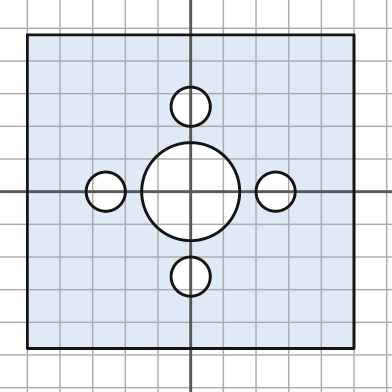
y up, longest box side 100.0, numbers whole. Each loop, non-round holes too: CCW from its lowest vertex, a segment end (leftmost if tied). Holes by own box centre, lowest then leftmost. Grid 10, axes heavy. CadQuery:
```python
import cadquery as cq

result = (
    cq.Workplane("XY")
    .moveTo(-50.0, -48.0)
    .lineTo(50.0, -48.0)
    .lineTo(50.0, 48.0)
    .lineTo(-50.0, 48.0)
    .close()
    .moveTo(0.0, -26.0)
    .circle(6.0)
    .moveTo(-26.0, 0.0)
    .circle(6.0)
    .moveTo(0.0, 0.0)
    .circle(15.0)
    .moveTo(26.0, 0.0)
    .circle(6.0)
    .moveTo(0.0, 26.0)
    .circle(6.0)
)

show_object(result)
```